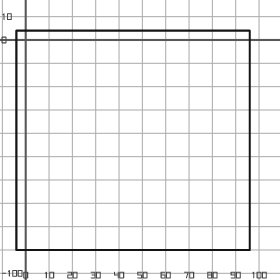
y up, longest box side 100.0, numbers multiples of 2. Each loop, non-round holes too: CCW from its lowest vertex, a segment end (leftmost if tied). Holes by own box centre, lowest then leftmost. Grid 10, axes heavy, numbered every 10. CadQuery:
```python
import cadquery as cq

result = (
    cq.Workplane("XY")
    .moveTo(-4.0, -90.0)
    .lineTo(96.0, -90.0)
    .lineTo(96.0, 4.0)
    .lineTo(-4.0, 4.0)
    .close()
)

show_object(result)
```